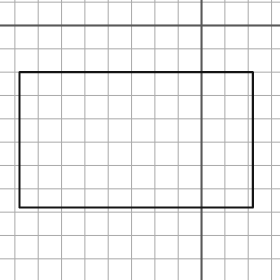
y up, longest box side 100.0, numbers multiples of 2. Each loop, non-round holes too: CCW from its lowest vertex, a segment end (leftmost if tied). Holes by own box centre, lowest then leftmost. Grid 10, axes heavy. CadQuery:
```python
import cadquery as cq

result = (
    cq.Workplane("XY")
    .moveTo(-78.0, -78.0)
    .lineTo(22.0, -78.0)
    .lineTo(22.0, -20.0)
    .lineTo(-78.0, -20.0)
    .close()
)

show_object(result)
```